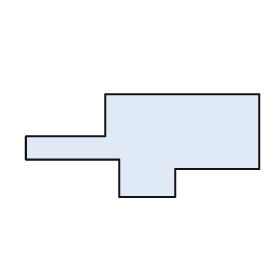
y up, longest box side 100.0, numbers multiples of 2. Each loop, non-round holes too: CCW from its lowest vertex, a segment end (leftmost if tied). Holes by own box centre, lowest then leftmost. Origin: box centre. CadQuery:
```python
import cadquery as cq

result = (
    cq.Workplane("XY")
    .moveTo(-10.0, -22.0)
    .lineTo(14.0, -22.0)
    .lineTo(14.0, -10.0)
    .lineTo(50.0, -10.0)
    .lineTo(50.0, 22.0)
    .lineTo(-16.0, 22.0)
    .lineTo(-16.0, 4.0)
    .lineTo(-50.0, 4.0)
    .lineTo(-50.0, -6.0)
    .lineTo(-10.0, -6.0)
    .close()
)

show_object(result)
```